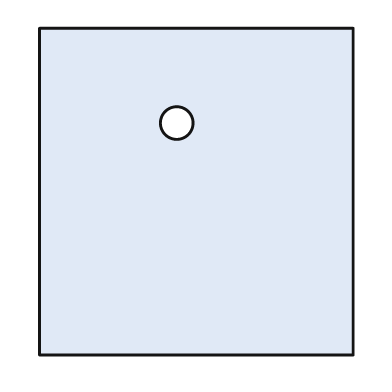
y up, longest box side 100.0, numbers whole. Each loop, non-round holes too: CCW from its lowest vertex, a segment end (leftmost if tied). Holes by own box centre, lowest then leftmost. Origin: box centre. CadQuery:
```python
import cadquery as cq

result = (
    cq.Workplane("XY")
    .moveTo(-48.0, -50.0)
    .lineTo(48.0, -50.0)
    .lineTo(48.0, 50.0)
    .lineTo(-48.0, 50.0)
    .close()
    .moveTo(-6.0, 21.0)
    .circle(5.0)
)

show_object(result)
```